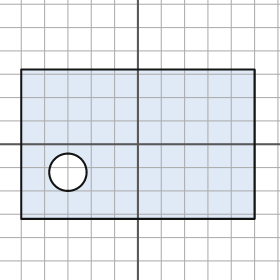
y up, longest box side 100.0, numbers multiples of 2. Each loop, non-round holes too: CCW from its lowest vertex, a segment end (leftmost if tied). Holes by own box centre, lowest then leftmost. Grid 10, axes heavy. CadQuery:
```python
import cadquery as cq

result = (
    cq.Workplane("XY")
    .moveTo(-50.0, -32.0)
    .lineTo(50.0, -32.0)
    .lineTo(50.0, 32.0)
    .lineTo(-50.0, 32.0)
    .close()
    .moveTo(-30.0, -12.0)
    .circle(8.0)
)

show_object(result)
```